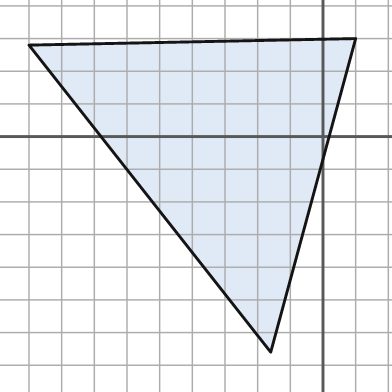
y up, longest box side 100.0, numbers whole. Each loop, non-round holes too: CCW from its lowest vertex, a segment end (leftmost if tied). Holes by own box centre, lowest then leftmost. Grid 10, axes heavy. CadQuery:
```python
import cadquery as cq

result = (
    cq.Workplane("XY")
    .moveTo(-16.0, -66.0)
    .lineTo(10.0, 30.0)
    .lineTo(-90.0, 28.0)
    .close()
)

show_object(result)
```